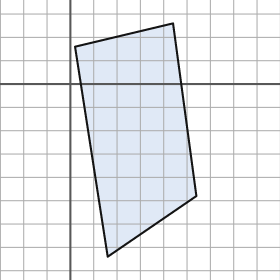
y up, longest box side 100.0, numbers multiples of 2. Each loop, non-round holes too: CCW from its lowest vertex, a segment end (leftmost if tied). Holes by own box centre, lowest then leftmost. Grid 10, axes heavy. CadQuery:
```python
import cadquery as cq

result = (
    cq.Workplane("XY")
    .moveTo(16.0, -74.0)
    .lineTo(54.0, -48.0)
    .lineTo(44.0, 26.0)
    .lineTo(2.0, 16.0)
    .close()
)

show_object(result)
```